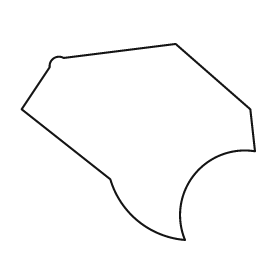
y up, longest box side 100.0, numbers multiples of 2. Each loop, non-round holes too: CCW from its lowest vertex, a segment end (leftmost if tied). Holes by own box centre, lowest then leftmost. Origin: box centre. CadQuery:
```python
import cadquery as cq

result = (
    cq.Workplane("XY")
    .moveTo(20.0, -42.0)
    .threePointArc((24.0, -14.0), (50.0, -4.0))
    .lineTo(48.0, 14.0)
    .lineTo(16.0, 42.0)
    .lineTo(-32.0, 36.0)
    .threePointArc((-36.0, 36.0), (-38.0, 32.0))
    .lineTo(-50.0, 14.0)
    .lineTo(-12.0, -16.0)
    .threePointArc((0.0, -34.0), (20.0, -42.0))
    .close()
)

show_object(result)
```